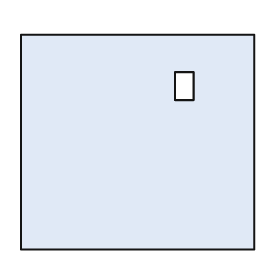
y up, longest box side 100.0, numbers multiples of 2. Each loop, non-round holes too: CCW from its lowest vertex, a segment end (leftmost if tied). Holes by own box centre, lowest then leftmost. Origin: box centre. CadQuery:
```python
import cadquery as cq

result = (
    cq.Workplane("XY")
    .moveTo(-50.0, -46.0)
    .lineTo(50.0, -46.0)
    .lineTo(50.0, 46.0)
    .lineTo(-50.0, 46.0)
    .close()
    .moveTo(16.0, 18.0)
    .lineTo(24.0, 18.0)
    .lineTo(24.0, 30.0)
    .lineTo(16.0, 30.0)
    .close()
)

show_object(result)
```